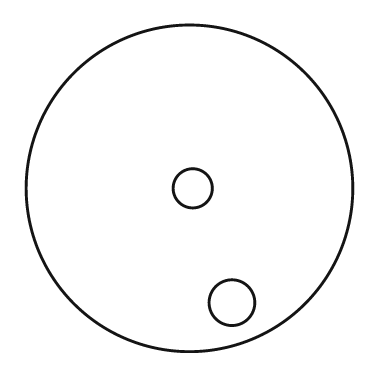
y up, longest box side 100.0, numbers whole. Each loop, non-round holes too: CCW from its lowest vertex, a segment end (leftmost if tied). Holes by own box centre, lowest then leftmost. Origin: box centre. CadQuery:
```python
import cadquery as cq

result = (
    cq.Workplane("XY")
    .moveTo(0.0, 0.0)
    .circle(50.0)
    .moveTo(13.0, -35.0)
    .circle(7.0)
    .moveTo(1.0, 0.0)
    .circle(6.0)
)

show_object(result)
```